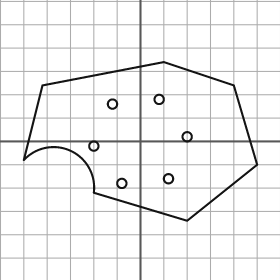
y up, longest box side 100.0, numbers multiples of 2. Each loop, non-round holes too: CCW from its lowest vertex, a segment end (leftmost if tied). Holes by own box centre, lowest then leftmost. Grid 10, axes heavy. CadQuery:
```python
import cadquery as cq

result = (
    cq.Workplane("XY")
    .moveTo(20.0, -34.0)
    .lineTo(50.0, -10.0)
    .lineTo(40.0, 24.0)
    .lineTo(10.0, 34.0)
    .lineTo(-42.0, 24.0)
    .lineTo(-50.0, -8.0)
    .threePointArc((-30.0, -4.0), (-20.0, -22.0))
    .close()
    .moveTo(-8.0, -18.0)
    .circle(2.0)
    .moveTo(12.0, -16.0)
    .circle(2.0)
    .moveTo(-20.0, -2.0)
    .circle(2.0)
    .moveTo(20.0, 2.0)
    .circle(2.0)
    .moveTo(-12.0, 16.0)
    .circle(2.0)
    .moveTo(8.0, 18.0)
    .circle(2.0)
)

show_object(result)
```